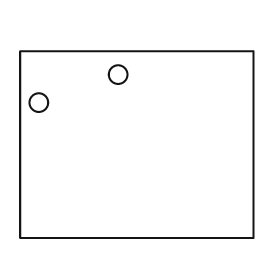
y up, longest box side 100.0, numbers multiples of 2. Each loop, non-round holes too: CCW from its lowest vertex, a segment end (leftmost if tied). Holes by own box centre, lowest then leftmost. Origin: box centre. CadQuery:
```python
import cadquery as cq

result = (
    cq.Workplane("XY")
    .moveTo(-50.0, -40.0)
    .lineTo(50.0, -40.0)
    .lineTo(50.0, 40.0)
    .lineTo(-50.0, 40.0)
    .close()
    .moveTo(-42.0, 18.0)
    .circle(4.0)
    .moveTo(-8.0, 30.0)
    .circle(4.0)
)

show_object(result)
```